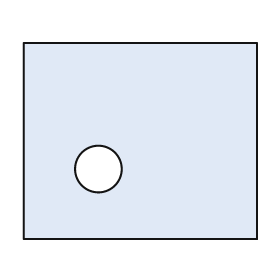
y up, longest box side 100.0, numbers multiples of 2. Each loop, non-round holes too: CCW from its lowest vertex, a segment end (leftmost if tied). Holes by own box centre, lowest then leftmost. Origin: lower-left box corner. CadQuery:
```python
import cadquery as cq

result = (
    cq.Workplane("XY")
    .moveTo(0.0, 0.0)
    .lineTo(100.0, 0.0)
    .lineTo(100.0, 84.0)
    .lineTo(0.0, 84.0)
    .close()
    .moveTo(32.0, 30.0)
    .circle(10.0)
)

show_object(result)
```